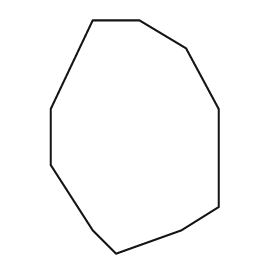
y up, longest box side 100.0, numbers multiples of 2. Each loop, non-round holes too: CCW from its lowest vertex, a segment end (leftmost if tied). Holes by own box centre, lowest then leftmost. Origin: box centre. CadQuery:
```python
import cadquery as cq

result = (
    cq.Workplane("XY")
    .moveTo(-8.0, -50.0)
    .lineTo(20.0, -40.0)
    .lineTo(36.0, -30.0)
    .lineTo(36.0, 12.0)
    .lineTo(22.0, 38.0)
    .lineTo(2.0, 50.0)
    .lineTo(-18.0, 50.0)
    .lineTo(-36.0, 12.0)
    .lineTo(-36.0, -12.0)
    .lineTo(-18.0, -40.0)
    .close()
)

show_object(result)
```